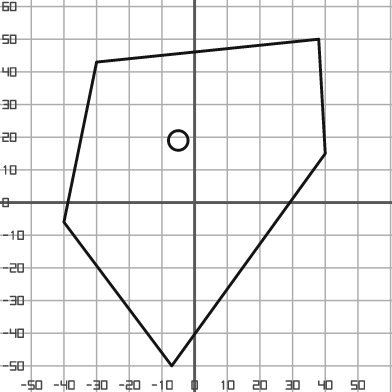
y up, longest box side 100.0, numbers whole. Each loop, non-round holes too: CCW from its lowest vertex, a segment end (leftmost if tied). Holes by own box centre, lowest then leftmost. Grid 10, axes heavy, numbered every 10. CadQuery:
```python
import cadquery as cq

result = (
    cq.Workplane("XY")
    .moveTo(-7.0, -50.0)
    .lineTo(40.0, 15.0)
    .lineTo(38.0, 50.0)
    .lineTo(-30.0, 43.0)
    .lineTo(-40.0, -6.0)
    .close()
    .moveTo(-5.0, 19.0)
    .circle(3.0)
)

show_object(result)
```